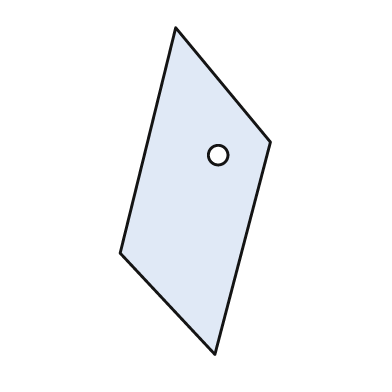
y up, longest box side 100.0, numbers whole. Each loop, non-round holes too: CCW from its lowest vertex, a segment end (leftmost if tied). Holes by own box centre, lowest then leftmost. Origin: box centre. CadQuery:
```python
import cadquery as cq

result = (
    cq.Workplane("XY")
    .moveTo(6.0, -50.0)
    .lineTo(23.0, 15.0)
    .lineTo(-6.0, 50.0)
    .lineTo(-23.0, -19.0)
    .close()
    .moveTo(7.0, 11.0)
    .circle(3.0)
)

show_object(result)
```